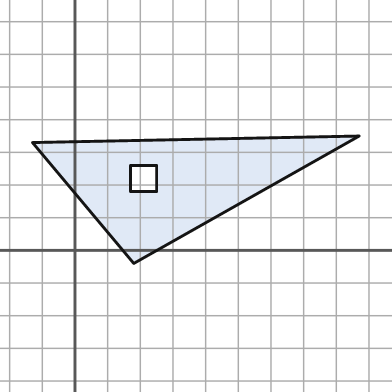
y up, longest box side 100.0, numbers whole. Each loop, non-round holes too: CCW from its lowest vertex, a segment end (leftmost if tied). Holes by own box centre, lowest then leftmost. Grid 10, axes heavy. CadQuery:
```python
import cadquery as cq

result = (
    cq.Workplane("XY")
    .moveTo(18.0, -4.0)
    .lineTo(87.0, 35.0)
    .lineTo(-13.0, 33.0)
    .close()
    .moveTo(17.0, 18.0)
    .lineTo(25.0, 18.0)
    .lineTo(25.0, 26.0)
    .lineTo(17.0, 26.0)
    .close()
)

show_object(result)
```